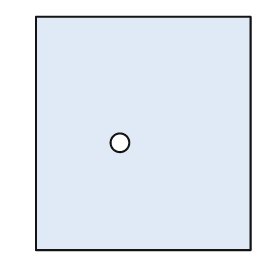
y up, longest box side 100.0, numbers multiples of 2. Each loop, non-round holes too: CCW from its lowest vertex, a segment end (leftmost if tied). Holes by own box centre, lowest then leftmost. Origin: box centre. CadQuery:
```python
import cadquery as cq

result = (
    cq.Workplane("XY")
    .moveTo(-46.0, -50.0)
    .lineTo(46.0, -50.0)
    .lineTo(46.0, 50.0)
    .lineTo(-46.0, 50.0)
    .close()
    .moveTo(-10.0, -4.0)
    .circle(4.0)
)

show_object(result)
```